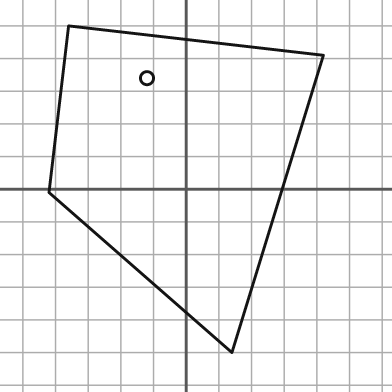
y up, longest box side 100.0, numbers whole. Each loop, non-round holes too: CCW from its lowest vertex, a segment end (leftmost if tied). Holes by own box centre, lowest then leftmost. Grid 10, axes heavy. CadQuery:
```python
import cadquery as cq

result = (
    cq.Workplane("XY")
    .moveTo(14.0, -50.0)
    .lineTo(42.0, 41.0)
    .lineTo(-36.0, 50.0)
    .lineTo(-42.0, -1.0)
    .close()
    .moveTo(-12.0, 34.0)
    .circle(2.0)
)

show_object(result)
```